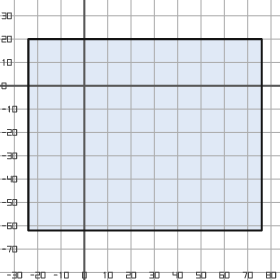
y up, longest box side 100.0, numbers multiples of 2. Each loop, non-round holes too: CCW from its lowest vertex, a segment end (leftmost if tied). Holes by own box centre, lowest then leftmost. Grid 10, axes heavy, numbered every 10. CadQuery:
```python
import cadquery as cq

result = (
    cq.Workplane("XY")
    .moveTo(-24.0, -62.0)
    .lineTo(76.0, -62.0)
    .lineTo(76.0, 20.0)
    .lineTo(-24.0, 20.0)
    .close()
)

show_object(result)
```